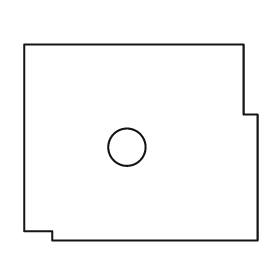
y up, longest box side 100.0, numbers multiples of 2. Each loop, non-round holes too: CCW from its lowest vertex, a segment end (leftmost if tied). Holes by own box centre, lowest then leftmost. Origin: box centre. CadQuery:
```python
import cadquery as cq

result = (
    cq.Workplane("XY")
    .moveTo(-38.0, -42.0)
    .lineTo(50.0, -42.0)
    .lineTo(50.0, 12.0)
    .lineTo(44.0, 12.0)
    .lineTo(44.0, 42.0)
    .lineTo(-50.0, 42.0)
    .lineTo(-50.0, -38.0)
    .lineTo(-38.0, -38.0)
    .close()
    .moveTo(-6.0, -2.0)
    .circle(8.0)
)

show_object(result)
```